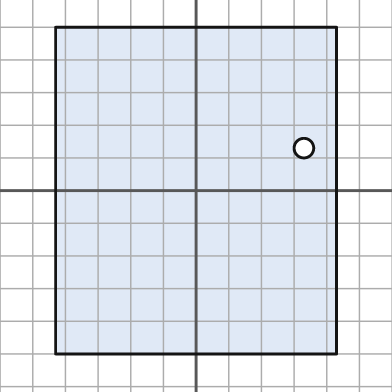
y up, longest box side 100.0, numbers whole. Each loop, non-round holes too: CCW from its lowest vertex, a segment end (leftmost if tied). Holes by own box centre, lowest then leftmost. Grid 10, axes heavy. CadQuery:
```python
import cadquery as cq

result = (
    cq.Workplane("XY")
    .moveTo(-43.0, -50.0)
    .lineTo(43.0, -50.0)
    .lineTo(43.0, 50.0)
    .lineTo(-43.0, 50.0)
    .close()
    .moveTo(33.0, 13.0)
    .circle(3.0)
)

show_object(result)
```